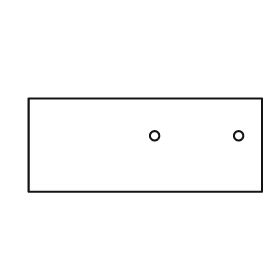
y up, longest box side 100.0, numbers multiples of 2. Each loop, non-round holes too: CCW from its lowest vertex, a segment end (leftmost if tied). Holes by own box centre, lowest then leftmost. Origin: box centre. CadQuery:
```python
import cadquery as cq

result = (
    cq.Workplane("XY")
    .moveTo(-50.0, -20.0)
    .lineTo(50.0, -20.0)
    .lineTo(50.0, 20.0)
    .lineTo(-50.0, 20.0)
    .close()
    .moveTo(4.0, 4.0)
    .circle(2.0)
    .moveTo(40.0, 4.0)
    .circle(2.0)
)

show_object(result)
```